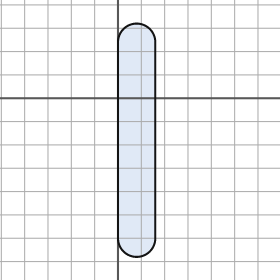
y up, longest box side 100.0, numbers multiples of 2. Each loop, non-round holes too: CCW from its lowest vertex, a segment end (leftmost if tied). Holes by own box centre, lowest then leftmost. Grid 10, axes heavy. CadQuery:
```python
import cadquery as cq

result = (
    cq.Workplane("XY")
    .moveTo(0.0, -60.0)
    .threePointArc((8.0, -68.0), (16.0, -60.0))
    .lineTo(16.0, 24.0)
    .threePointArc((8.0, 32.0), (0.0, 24.0))
    .close()
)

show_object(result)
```